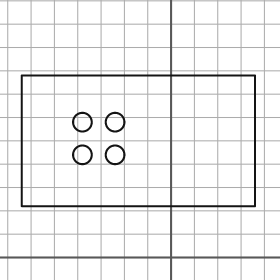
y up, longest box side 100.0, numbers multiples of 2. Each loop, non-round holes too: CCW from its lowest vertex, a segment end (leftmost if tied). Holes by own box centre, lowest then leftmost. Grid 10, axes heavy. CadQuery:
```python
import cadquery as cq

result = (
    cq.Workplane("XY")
    .moveTo(-64.0, 22.0)
    .lineTo(36.0, 22.0)
    .lineTo(36.0, 78.0)
    .lineTo(-64.0, 78.0)
    .close()
    .moveTo(-38.0, 44.0)
    .circle(4.0)
    .moveTo(-24.0, 44.0)
    .circle(4.0)
    .moveTo(-38.0, 58.0)
    .circle(4.0)
    .moveTo(-24.0, 58.0)
    .circle(4.0)
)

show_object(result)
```